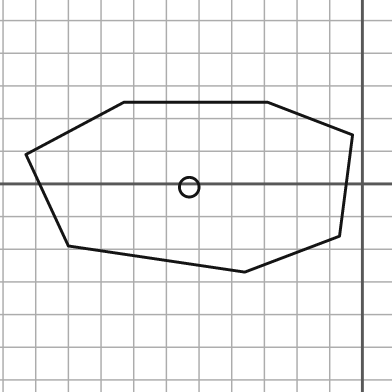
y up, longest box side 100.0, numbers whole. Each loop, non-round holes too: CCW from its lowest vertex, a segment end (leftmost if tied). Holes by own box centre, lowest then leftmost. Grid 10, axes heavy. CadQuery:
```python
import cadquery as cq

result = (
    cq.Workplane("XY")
    .moveTo(-36.0, -27.0)
    .lineTo(-7.0, -16.0)
    .lineTo(-3.0, 15.0)
    .lineTo(-29.0, 25.0)
    .lineTo(-73.0, 25.0)
    .lineTo(-103.0, 9.0)
    .lineTo(-90.0, -19.0)
    .close()
    .moveTo(-53.0, -1.0)
    .circle(3.0)
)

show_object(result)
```